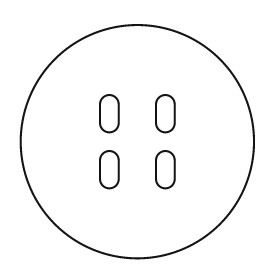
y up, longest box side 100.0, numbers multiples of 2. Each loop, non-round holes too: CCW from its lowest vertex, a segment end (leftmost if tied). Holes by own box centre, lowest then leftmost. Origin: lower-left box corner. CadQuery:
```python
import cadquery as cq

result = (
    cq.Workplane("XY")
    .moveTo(50.0, 50.0)
    .circle(50.0)
    .moveTo(34.0, 34.0)
    .threePointArc((38.0, 30.0), (42.0, 34.0))
    .lineTo(42.0, 42.0)
    .threePointArc((38.0, 46.0), (34.0, 42.0))
    .close()
    .moveTo(58.0, 34.0)
    .threePointArc((62.0, 30.0), (66.0, 34.0))
    .lineTo(66.0, 42.0)
    .threePointArc((62.0, 46.0), (58.0, 42.0))
    .close()
    .moveTo(34.0, 58.0)
    .threePointArc((38.0, 54.0), (42.0, 58.0))
    .lineTo(42.0, 66.0)
    .threePointArc((38.0, 70.0), (34.0, 66.0))
    .close()
    .moveTo(58.0, 58.0)
    .threePointArc((62.0, 54.0), (66.0, 58.0))
    .lineTo(66.0, 66.0)
    .threePointArc((62.0, 70.0), (58.0, 66.0))
    .close()
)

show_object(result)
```